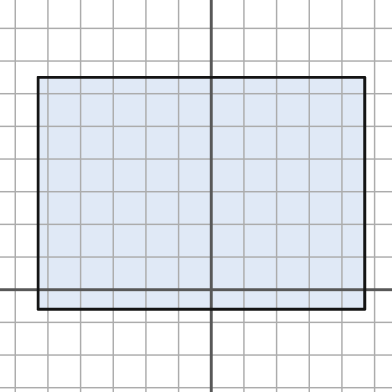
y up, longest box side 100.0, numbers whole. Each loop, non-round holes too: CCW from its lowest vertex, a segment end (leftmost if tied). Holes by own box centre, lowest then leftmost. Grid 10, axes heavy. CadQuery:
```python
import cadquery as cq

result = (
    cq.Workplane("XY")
    .moveTo(-53.0, -6.0)
    .lineTo(47.0, -6.0)
    .lineTo(47.0, 65.0)
    .lineTo(-53.0, 65.0)
    .close()
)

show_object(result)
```